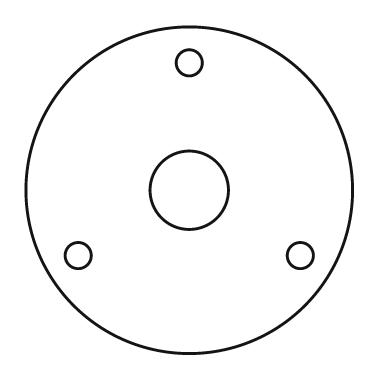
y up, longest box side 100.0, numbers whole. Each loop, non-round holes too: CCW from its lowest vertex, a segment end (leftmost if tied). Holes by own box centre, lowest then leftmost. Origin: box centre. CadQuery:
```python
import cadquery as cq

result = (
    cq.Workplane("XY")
    .moveTo(0.0, 0.0)
    .circle(50.0)
    .moveTo(-34.0, -20.0)
    .circle(4.0)
    .moveTo(34.0, -20.0)
    .circle(4.0)
    .moveTo(0.0, 0.0)
    .circle(12.0)
    .moveTo(0.0, 39.0)
    .circle(4.0)
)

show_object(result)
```